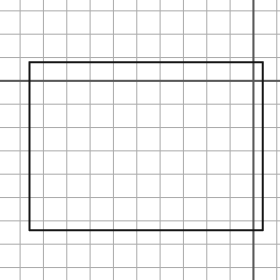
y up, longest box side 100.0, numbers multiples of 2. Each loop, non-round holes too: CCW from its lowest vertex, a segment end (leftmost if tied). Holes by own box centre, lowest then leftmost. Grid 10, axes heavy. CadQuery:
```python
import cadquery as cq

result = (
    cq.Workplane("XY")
    .moveTo(-96.0, -64.0)
    .lineTo(4.0, -64.0)
    .lineTo(4.0, 8.0)
    .lineTo(-96.0, 8.0)
    .close()
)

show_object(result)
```